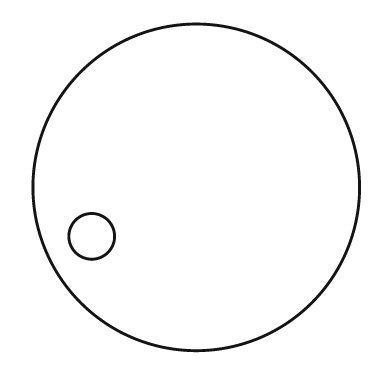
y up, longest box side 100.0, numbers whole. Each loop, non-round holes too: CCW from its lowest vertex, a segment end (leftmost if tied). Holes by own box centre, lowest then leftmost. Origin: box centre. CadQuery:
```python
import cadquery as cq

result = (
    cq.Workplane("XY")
    .moveTo(0.0, 0.0)
    .circle(50.0)
    .moveTo(-32.0, -15.0)
    .circle(7.0)
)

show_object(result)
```